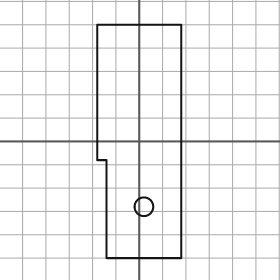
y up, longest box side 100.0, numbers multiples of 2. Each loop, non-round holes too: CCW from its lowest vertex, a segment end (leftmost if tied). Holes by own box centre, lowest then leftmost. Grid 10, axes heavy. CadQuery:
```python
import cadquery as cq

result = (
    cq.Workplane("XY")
    .moveTo(-14.0, -50.0)
    .lineTo(18.0, -50.0)
    .lineTo(18.0, 50.0)
    .lineTo(-18.0, 50.0)
    .lineTo(-18.0, -8.0)
    .lineTo(-14.0, -8.0)
    .close()
    .moveTo(2.0, -28.0)
    .circle(4.0)
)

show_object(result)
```